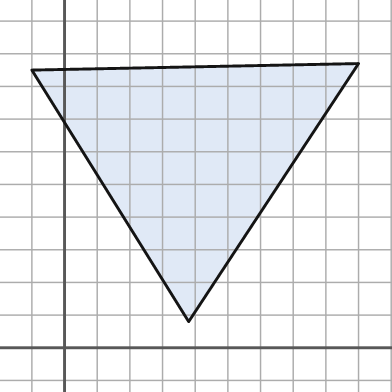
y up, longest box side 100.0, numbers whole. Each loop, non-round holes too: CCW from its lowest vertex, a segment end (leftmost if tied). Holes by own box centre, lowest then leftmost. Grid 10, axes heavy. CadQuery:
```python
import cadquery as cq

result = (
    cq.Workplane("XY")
    .moveTo(38.0, 8.0)
    .lineTo(90.0, 87.0)
    .lineTo(-10.0, 85.0)
    .close()
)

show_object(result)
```